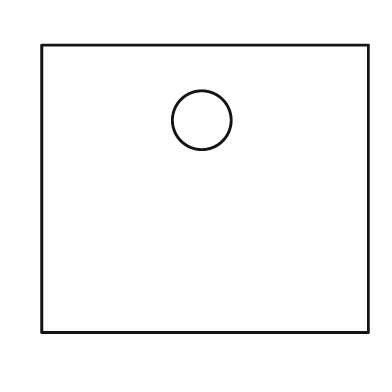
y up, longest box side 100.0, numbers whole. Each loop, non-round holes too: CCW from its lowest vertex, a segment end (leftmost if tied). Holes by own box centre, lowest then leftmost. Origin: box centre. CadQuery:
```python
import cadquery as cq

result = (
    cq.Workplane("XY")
    .moveTo(-50.0, -44.0)
    .lineTo(50.0, -44.0)
    .lineTo(50.0, 44.0)
    .lineTo(-50.0, 44.0)
    .close()
    .moveTo(-1.0, 21.0)
    .circle(9.0)
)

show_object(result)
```